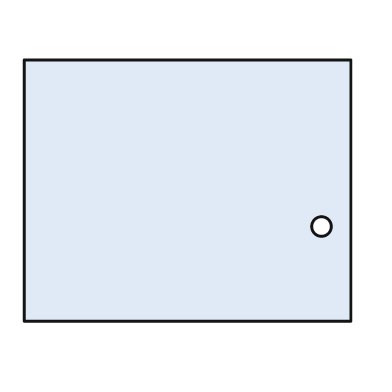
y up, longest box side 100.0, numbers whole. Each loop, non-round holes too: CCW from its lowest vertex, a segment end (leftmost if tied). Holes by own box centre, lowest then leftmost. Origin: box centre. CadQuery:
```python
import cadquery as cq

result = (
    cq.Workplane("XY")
    .moveTo(-50.0, -40.0)
    .lineTo(50.0, -40.0)
    .lineTo(50.0, 40.0)
    .lineTo(-50.0, 40.0)
    .close()
    .moveTo(41.0, -11.0)
    .circle(3.0)
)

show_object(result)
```